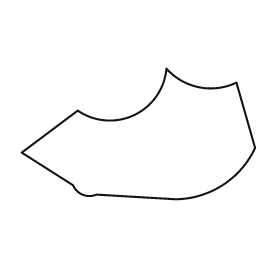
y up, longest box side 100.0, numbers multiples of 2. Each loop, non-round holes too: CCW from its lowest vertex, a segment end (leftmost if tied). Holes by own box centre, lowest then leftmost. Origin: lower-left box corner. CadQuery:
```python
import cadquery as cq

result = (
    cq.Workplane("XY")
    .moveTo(66.0, 0.0)
    .threePointArc((86.0, 6.0), (100.0, 22.0))
    .lineTo(92.0, 50.0)
    .threePointArc((76.0, 48.0), (62.0, 56.0))
    .threePointArc((48.0, 36.0), (24.0, 38.0))
    .lineTo(0.0, 20.0)
    .lineTo(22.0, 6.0)
    .threePointArc((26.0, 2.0), (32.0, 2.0))
    .close()
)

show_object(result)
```